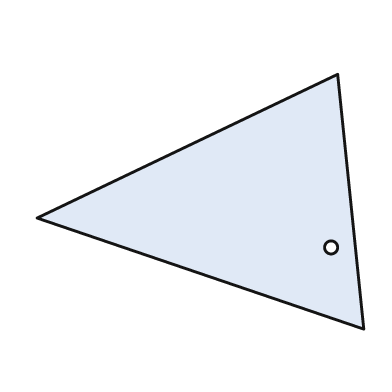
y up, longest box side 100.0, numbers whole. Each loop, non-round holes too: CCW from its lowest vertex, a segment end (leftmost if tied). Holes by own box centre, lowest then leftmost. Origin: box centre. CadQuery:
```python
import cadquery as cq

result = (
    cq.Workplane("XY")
    .moveTo(50.0, -39.0)
    .lineTo(42.0, 39.0)
    .lineTo(-50.0, -5.0)
    .close()
    .moveTo(40.0, -14.0)
    .circle(2.0)
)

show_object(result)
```